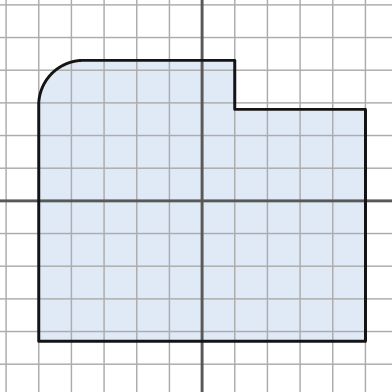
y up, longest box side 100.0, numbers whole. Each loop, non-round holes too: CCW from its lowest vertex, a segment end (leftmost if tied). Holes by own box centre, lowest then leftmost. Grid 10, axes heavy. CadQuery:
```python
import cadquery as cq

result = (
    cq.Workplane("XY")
    .moveTo(-50.0, -43.0)
    .lineTo(50.0, -43.0)
    .lineTo(50.0, 28.0)
    .lineTo(10.0, 28.0)
    .lineTo(10.0, 43.0)
    .lineTo(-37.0, 43.0)
    .threePointArc((-46.0, 39.0), (-50.0, 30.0))
    .close()
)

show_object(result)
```